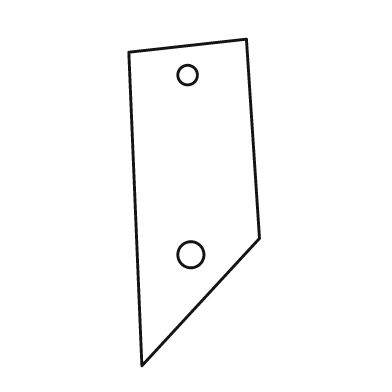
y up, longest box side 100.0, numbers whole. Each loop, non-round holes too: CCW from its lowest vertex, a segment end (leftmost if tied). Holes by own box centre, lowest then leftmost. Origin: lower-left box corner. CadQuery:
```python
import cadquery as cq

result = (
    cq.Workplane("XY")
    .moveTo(4.0, 0.0)
    .lineTo(40.0, 39.0)
    .lineTo(36.0, 100.0)
    .lineTo(0.0, 96.0)
    .close()
    .moveTo(19.0, 34.0)
    .circle(4.0)
    .moveTo(18.0, 89.0)
    .circle(3.0)
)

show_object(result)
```